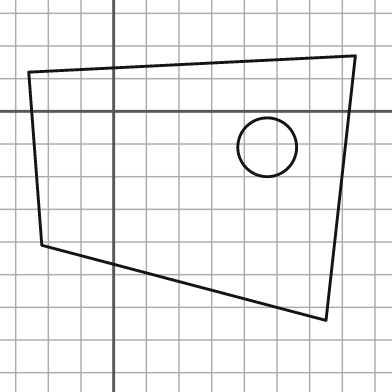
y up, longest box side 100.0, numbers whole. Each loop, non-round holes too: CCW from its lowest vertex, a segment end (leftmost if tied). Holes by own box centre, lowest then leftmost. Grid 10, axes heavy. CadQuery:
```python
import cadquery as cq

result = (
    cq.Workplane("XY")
    .moveTo(65.0, -64.0)
    .lineTo(74.0, 17.0)
    .lineTo(-26.0, 12.0)
    .lineTo(-22.0, -41.0)
    .close()
    .moveTo(47.0, -11.0)
    .circle(9.0)
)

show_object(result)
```